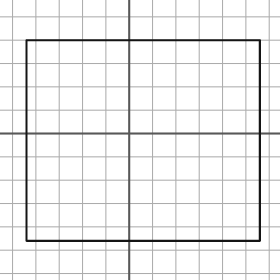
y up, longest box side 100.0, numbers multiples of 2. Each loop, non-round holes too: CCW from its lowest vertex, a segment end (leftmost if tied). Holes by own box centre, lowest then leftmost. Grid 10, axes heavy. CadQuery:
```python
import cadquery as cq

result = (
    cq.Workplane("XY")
    .moveTo(-44.0, -46.0)
    .lineTo(56.0, -46.0)
    .lineTo(56.0, 40.0)
    .lineTo(-44.0, 40.0)
    .close()
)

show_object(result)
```